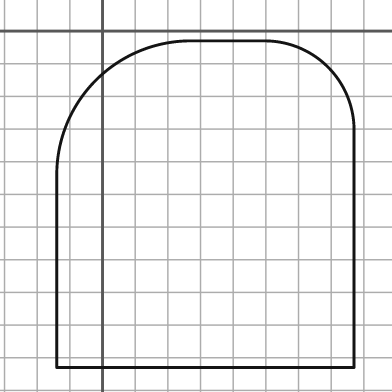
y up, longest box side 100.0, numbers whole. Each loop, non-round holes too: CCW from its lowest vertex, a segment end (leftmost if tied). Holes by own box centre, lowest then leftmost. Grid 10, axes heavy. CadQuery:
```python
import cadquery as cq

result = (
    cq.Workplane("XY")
    .moveTo(-14.0, -103.0)
    .lineTo(77.0, -103.0)
    .lineTo(77.0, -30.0)
    .threePointArc((69.0, -11.0), (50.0, -3.0))
    .lineTo(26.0, -3.0)
    .threePointArc((-2.0, -15.0), (-14.0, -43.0))
    .close()
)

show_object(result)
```